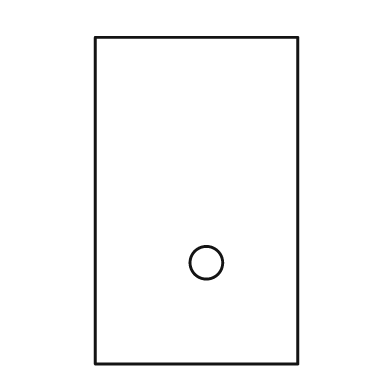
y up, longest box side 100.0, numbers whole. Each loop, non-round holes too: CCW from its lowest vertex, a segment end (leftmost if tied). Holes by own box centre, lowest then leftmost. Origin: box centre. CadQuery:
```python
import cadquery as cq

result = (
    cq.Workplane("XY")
    .moveTo(-31.0, -50.0)
    .lineTo(31.0, -50.0)
    .lineTo(31.0, 50.0)
    .lineTo(-31.0, 50.0)
    .close()
    .moveTo(3.0, -19.0)
    .circle(5.0)
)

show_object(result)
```